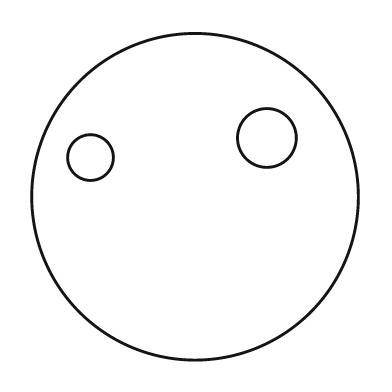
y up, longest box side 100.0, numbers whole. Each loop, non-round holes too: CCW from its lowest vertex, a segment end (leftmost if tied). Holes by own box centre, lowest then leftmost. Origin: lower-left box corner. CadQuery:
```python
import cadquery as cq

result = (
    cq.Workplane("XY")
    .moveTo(50.0, 50.0)
    .circle(50.0)
    .moveTo(18.0, 62.0)
    .circle(7.0)
    .moveTo(72.0, 68.0)
    .circle(9.0)
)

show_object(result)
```